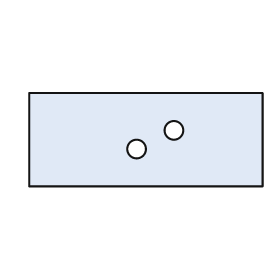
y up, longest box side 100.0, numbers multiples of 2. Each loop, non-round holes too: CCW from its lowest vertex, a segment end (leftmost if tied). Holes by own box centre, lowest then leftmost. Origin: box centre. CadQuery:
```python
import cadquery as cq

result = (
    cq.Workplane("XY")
    .moveTo(-50.0, -20.0)
    .lineTo(50.0, -20.0)
    .lineTo(50.0, 20.0)
    .lineTo(-50.0, 20.0)
    .close()
    .moveTo(-4.0, -4.0)
    .circle(4.0)
    .moveTo(12.0, 4.0)
    .circle(4.0)
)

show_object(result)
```